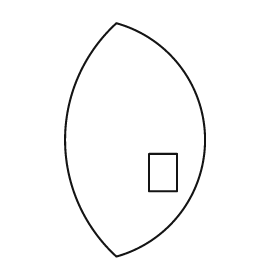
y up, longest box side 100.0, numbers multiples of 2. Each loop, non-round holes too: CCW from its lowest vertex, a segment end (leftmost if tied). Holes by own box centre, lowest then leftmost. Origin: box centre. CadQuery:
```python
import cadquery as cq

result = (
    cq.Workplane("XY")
    .moveTo(-8.0, -50.0)
    .threePointArc((30.0, 0.0), (-8.0, 50.0))
    .threePointArc((-30.0, 0.0), (-8.0, -50.0))
    .close()
    .moveTo(6.0, -22.0)
    .lineTo(18.0, -22.0)
    .lineTo(18.0, -6.0)
    .lineTo(6.0, -6.0)
    .close()
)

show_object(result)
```